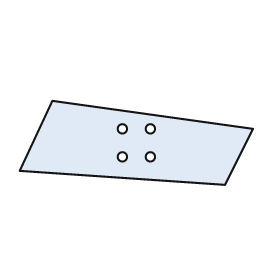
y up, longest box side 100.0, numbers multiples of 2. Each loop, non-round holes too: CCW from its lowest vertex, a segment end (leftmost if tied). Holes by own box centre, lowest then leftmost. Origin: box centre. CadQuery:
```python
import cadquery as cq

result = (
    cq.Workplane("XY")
    .moveTo(38.0, -18.0)
    .lineTo(50.0, 6.0)
    .lineTo(-36.0, 18.0)
    .lineTo(-50.0, -12.0)
    .close()
    .moveTo(-6.0, -6.0)
    .circle(2.0)
    .moveTo(6.0, -6.0)
    .circle(2.0)
    .moveTo(-6.0, 6.0)
    .circle(2.0)
    .moveTo(6.0, 6.0)
    .circle(2.0)
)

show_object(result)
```